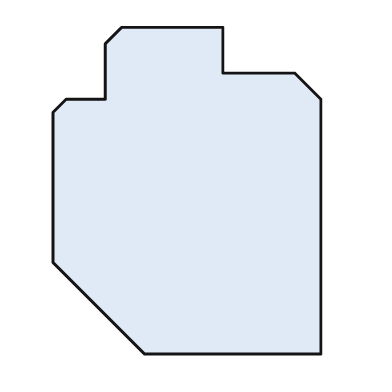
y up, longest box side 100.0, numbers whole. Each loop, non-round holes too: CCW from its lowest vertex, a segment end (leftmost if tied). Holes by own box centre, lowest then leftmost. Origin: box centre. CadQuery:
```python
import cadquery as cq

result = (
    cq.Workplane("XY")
    .moveTo(-13.0, -50.0)
    .lineTo(41.0, -50.0)
    .lineTo(41.0, 28.0)
    .lineTo(33.0, 36.0)
    .lineTo(11.0, 36.0)
    .lineTo(11.0, 50.0)
    .lineTo(-20.0, 50.0)
    .lineTo(-25.0, 45.0)
    .lineTo(-25.0, 28.0)
    .lineTo(-37.0, 28.0)
    .lineTo(-41.0, 24.0)
    .lineTo(-41.0, -22.0)
    .close()
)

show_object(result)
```